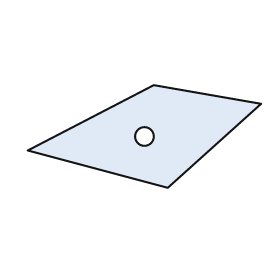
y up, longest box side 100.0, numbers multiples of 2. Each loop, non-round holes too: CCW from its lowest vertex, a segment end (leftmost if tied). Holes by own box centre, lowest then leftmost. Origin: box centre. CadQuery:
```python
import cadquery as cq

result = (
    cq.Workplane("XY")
    .moveTo(10.0, -22.0)
    .lineTo(50.0, 14.0)
    .lineTo(4.0, 22.0)
    .lineTo(-50.0, -6.0)
    .close()
    .moveTo(0.0, 0.0)
    .circle(4.0)
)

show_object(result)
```